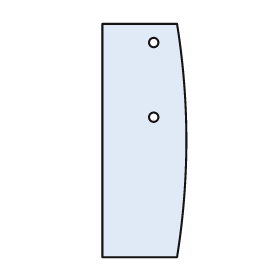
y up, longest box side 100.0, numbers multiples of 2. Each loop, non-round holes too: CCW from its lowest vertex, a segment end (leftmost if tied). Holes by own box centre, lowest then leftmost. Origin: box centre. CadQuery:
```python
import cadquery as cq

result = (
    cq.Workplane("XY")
    .moveTo(-18.0, -50.0)
    .lineTo(14.0, -50.0)
    .threePointArc((18.0, 0.0), (14.0, 50.0))
    .lineTo(-18.0, 50.0)
    .close()
    .moveTo(4.0, 10.0)
    .circle(2.0)
    .moveTo(4.0, 42.0)
    .circle(2.0)
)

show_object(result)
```